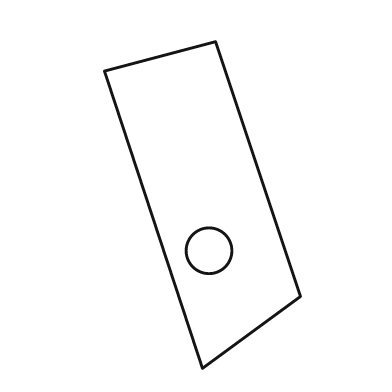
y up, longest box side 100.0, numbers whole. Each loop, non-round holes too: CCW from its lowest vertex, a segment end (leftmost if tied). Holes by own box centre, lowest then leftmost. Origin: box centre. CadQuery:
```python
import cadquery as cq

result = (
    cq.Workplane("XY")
    .moveTo(0.0, -50.0)
    .lineTo(30.0, -28.0)
    .lineTo(4.0, 50.0)
    .lineTo(-30.0, 41.0)
    .close()
    .moveTo(2.0, -14.0)
    .circle(7.0)
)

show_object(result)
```